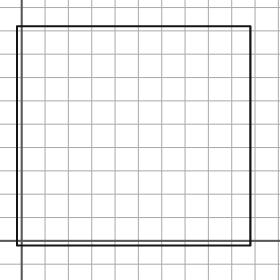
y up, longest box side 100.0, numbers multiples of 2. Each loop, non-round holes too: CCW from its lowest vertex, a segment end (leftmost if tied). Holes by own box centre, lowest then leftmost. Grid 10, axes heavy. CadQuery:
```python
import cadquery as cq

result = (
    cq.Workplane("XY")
    .moveTo(-2.0, -2.0)
    .lineTo(98.0, -2.0)
    .lineTo(98.0, 92.0)
    .lineTo(-2.0, 92.0)
    .close()
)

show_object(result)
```